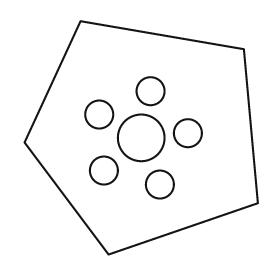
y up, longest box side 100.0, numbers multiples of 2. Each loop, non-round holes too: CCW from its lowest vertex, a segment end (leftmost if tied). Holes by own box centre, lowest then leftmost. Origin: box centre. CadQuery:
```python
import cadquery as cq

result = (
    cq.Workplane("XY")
    .moveTo(-14.0, -50.0)
    .lineTo(50.0, -28.0)
    .lineTo(44.0, 38.0)
    .lineTo(-26.0, 50.0)
    .lineTo(-50.0, -2.0)
    .close()
    .moveTo(8.0, -20.0)
    .circle(6.0)
    .moveTo(-16.0, -14.0)
    .circle(6.0)
    .moveTo(0.0, 0.0)
    .circle(10.0)
    .moveTo(20.0, 2.0)
    .circle(6.0)
    .moveTo(-18.0, 10.0)
    .circle(6.0)
    .moveTo(4.0, 20.0)
    .circle(6.0)
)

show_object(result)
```